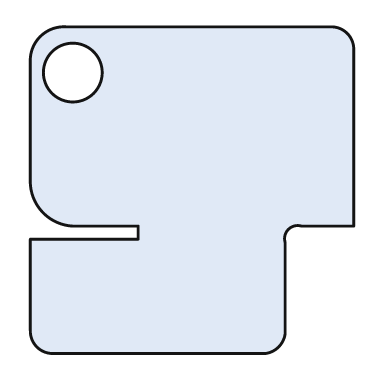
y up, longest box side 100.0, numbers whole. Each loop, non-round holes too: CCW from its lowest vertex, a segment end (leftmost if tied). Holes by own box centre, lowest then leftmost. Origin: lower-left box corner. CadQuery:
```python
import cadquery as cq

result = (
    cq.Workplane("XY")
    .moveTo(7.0, 0.0)
    .lineTo(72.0, 0.0)
    .threePointArc((76.0, 2.0), (78.0, 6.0))
    .lineTo(78.0, 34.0)
    .threePointArc((79.0, 38.0), (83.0, 39.0))
    .lineTo(99.0, 39.0)
    .lineTo(99.0, 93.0)
    .threePointArc((97.0, 98.0), (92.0, 100.0))
    .lineTo(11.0, 100.0)
    .threePointArc((3.0, 97.0), (0.0, 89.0))
    .lineTo(0.0, 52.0)
    .threePointArc((4.0, 43.0), (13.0, 39.0))
    .lineTo(33.0, 39.0)
    .lineTo(33.0, 35.0)
    .lineTo(0.0, 35.0)
    .lineTo(0.0, 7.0)
    .threePointArc((2.0, 2.0), (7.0, 0.0))
    .close()
    .moveTo(13.0, 86.0)
    .circle(9.0)
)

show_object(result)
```